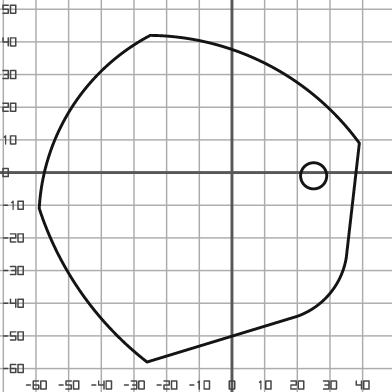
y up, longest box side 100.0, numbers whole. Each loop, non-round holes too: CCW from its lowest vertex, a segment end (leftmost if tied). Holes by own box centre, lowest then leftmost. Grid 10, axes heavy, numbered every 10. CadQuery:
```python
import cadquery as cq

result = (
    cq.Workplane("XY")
    .moveTo(-26.0, -58.0)
    .lineTo(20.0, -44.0)
    .threePointArc((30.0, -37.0), (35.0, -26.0))
    .lineTo(39.0, 9.0)
    .threePointArc((11.0, 33.0), (-25.0, 42.0))
    .threePointArc((-49.0, 20.0), (-59.0, -11.0))
    .threePointArc((-46.0, -37.0), (-26.0, -58.0))
    .close()
    .moveTo(25.0, -1.0)
    .circle(4.0)
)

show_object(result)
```